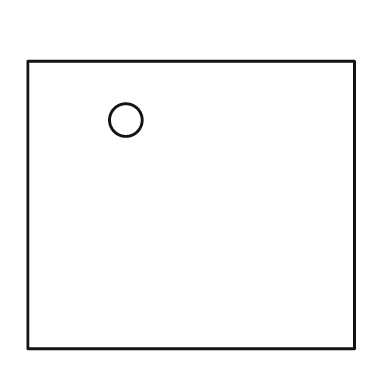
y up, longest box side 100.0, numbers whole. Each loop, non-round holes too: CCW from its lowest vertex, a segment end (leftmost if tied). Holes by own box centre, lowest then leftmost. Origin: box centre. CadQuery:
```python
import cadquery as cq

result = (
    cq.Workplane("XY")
    .moveTo(-50.0, -44.0)
    .lineTo(50.0, -44.0)
    .lineTo(50.0, 44.0)
    .lineTo(-50.0, 44.0)
    .close()
    .moveTo(-20.0, 26.0)
    .circle(5.0)
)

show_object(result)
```